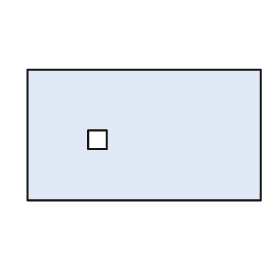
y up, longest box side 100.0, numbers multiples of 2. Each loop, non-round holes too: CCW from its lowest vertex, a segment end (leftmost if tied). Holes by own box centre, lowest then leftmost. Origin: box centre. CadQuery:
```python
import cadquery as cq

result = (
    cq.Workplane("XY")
    .moveTo(-50.0, -28.0)
    .lineTo(50.0, -28.0)
    .lineTo(50.0, 28.0)
    .lineTo(-50.0, 28.0)
    .close()
    .moveTo(-24.0, -6.0)
    .lineTo(-16.0, -6.0)
    .lineTo(-16.0, 2.0)
    .lineTo(-24.0, 2.0)
    .close()
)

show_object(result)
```